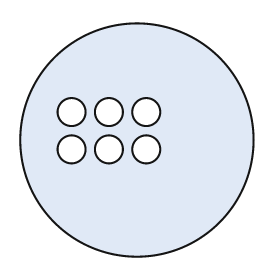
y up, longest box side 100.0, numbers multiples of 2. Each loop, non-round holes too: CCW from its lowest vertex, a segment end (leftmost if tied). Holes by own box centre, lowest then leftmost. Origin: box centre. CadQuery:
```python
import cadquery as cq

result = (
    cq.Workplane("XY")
    .moveTo(0.0, 0.0)
    .circle(50.0)
    .moveTo(-28.0, -4.0)
    .circle(6.0)
    .moveTo(-12.0, -4.0)
    .circle(6.0)
    .moveTo(4.0, -4.0)
    .circle(6.0)
    .moveTo(-28.0, 12.0)
    .circle(6.0)
    .moveTo(-12.0, 12.0)
    .circle(6.0)
    .moveTo(4.0, 12.0)
    .circle(6.0)
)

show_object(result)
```